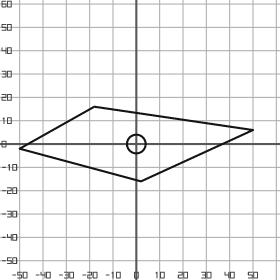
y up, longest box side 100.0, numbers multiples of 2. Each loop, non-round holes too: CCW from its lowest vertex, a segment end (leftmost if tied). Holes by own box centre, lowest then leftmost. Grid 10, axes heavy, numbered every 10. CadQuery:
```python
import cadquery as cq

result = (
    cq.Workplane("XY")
    .moveTo(2.0, -16.0)
    .lineTo(50.0, 6.0)
    .lineTo(-18.0, 16.0)
    .lineTo(-50.0, -2.0)
    .close()
    .moveTo(0.0, 0.0)
    .circle(4.0)
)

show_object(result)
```